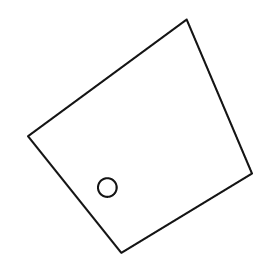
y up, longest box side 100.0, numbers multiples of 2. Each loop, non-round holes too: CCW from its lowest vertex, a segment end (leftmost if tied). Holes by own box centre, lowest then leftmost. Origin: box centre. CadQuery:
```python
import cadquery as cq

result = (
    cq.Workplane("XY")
    .moveTo(-8.0, -50.0)
    .lineTo(48.0, -16.0)
    .lineTo(20.0, 50.0)
    .lineTo(-48.0, 0.0)
    .close()
    .moveTo(-14.0, -22.0)
    .circle(4.0)
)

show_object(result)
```